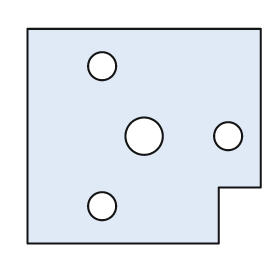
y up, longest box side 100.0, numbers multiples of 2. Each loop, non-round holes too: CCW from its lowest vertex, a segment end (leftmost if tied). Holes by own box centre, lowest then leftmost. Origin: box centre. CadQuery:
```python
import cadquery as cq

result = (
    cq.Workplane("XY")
    .moveTo(-50.0, -46.0)
    .lineTo(32.0, -46.0)
    .lineTo(32.0, -22.0)
    .lineTo(50.0, -22.0)
    .lineTo(50.0, 46.0)
    .lineTo(-50.0, 46.0)
    .close()
    .moveTo(-18.0, -30.0)
    .circle(6.0)
    .moveTo(0.0, 0.0)
    .circle(8.0)
    .moveTo(36.0, 0.0)
    .circle(6.0)
    .moveTo(-18.0, 30.0)
    .circle(6.0)
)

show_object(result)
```